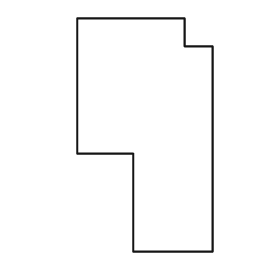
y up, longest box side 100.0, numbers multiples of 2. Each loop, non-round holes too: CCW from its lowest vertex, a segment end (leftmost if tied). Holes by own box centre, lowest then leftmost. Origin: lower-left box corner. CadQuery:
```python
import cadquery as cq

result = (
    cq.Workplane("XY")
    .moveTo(24.0, 0.0)
    .lineTo(58.0, 0.0)
    .lineTo(58.0, 88.0)
    .lineTo(46.0, 88.0)
    .lineTo(46.0, 100.0)
    .lineTo(0.0, 100.0)
    .lineTo(0.0, 42.0)
    .lineTo(24.0, 42.0)
    .close()
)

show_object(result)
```